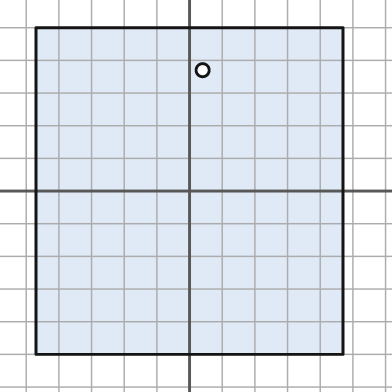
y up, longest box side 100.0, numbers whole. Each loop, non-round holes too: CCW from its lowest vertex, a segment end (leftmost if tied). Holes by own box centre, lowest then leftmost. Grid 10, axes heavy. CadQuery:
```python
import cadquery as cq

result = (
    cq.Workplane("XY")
    .moveTo(-47.0, -50.0)
    .lineTo(47.0, -50.0)
    .lineTo(47.0, 50.0)
    .lineTo(-47.0, 50.0)
    .close()
    .moveTo(4.0, 37.0)
    .circle(2.0)
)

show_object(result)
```